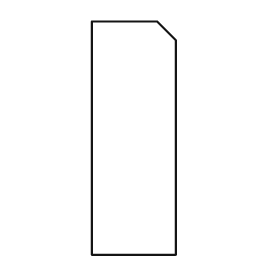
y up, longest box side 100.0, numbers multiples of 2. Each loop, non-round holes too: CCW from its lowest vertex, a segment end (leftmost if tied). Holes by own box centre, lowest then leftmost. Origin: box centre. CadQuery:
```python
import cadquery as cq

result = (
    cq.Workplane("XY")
    .moveTo(-18.0, -50.0)
    .lineTo(18.0, -50.0)
    .lineTo(18.0, 42.0)
    .lineTo(10.0, 50.0)
    .lineTo(-18.0, 50.0)
    .close()
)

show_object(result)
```